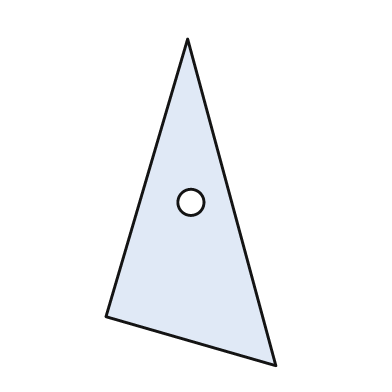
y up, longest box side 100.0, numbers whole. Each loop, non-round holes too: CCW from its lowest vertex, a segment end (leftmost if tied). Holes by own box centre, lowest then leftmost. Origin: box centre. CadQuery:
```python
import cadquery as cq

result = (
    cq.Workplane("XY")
    .moveTo(26.0, -50.0)
    .lineTo(-1.0, 50.0)
    .lineTo(-26.0, -35.0)
    .close()
    .moveTo(0.0, 0.0)
    .circle(4.0)
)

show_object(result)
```